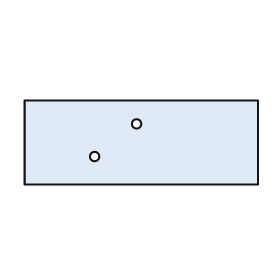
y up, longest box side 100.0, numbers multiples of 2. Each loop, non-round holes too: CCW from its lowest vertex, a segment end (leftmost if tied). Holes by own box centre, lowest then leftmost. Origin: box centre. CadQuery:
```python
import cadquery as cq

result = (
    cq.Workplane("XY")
    .moveTo(-50.0, -18.0)
    .lineTo(50.0, -18.0)
    .lineTo(50.0, 18.0)
    .lineTo(-50.0, 18.0)
    .close()
    .moveTo(-20.0, -6.0)
    .circle(2.0)
    .moveTo(-2.0, 8.0)
    .circle(2.0)
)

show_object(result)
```